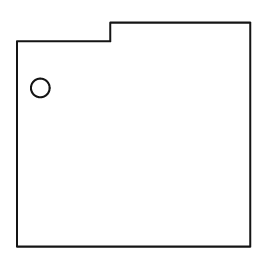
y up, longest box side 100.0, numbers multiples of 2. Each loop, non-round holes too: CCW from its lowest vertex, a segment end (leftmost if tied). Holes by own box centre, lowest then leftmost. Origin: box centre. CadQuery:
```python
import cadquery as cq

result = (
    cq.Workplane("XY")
    .moveTo(-50.0, -48.0)
    .lineTo(50.0, -48.0)
    .lineTo(50.0, 48.0)
    .lineTo(-10.0, 48.0)
    .lineTo(-10.0, 40.0)
    .lineTo(-50.0, 40.0)
    .close()
    .moveTo(-40.0, 20.0)
    .circle(4.0)
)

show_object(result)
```